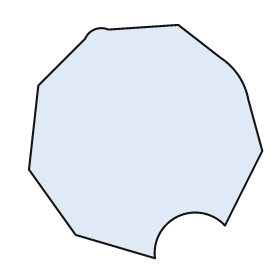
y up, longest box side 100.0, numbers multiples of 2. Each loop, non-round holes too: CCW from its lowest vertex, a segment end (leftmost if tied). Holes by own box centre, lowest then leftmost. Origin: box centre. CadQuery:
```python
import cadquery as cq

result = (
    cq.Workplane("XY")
    .moveTo(4.0, -50.0)
    .threePointArc((14.0, -32.0), (34.0, -36.0))
    .lineTo(50.0, -4.0)
    .lineTo(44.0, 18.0)
    .threePointArc((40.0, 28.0), (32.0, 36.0))
    .lineTo(14.0, 50.0)
    .lineTo(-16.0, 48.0)
    .threePointArc((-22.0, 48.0), (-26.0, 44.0))
    .lineTo(-46.0, 24.0)
    .lineTo(-50.0, -12.0)
    .lineTo(-30.0, -40.0)
    .close()
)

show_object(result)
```